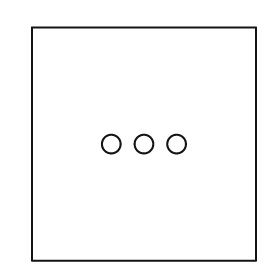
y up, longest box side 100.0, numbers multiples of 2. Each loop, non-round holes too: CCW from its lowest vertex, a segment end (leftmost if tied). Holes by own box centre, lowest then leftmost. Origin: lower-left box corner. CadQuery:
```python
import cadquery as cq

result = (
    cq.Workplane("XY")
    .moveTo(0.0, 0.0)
    .lineTo(96.0, 0.0)
    .lineTo(96.0, 100.0)
    .lineTo(0.0, 100.0)
    .close()
    .moveTo(34.0, 50.0)
    .circle(4.0)
    .moveTo(48.0, 50.0)
    .circle(4.0)
    .moveTo(62.0, 50.0)
    .circle(4.0)
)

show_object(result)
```